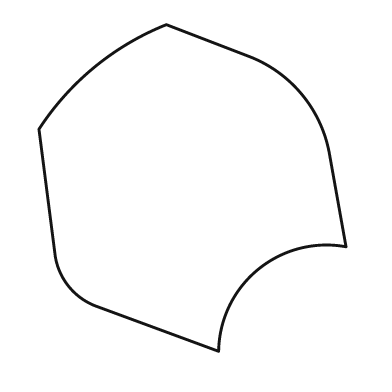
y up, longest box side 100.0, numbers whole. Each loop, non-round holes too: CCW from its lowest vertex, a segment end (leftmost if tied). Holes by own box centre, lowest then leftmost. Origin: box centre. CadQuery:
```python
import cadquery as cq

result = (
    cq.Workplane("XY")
    .moveTo(8.0, -50.0)
    .threePointArc((20.0, -25.0), (47.0, -18.0))
    .lineTo(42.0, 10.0)
    .threePointArc((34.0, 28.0), (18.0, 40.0))
    .lineTo(-8.0, 50.0)
    .threePointArc((-30.0, 37.0), (-47.0, 18.0))
    .lineTo(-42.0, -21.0)
    .threePointArc((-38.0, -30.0), (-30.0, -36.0))
    .close()
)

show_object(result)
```